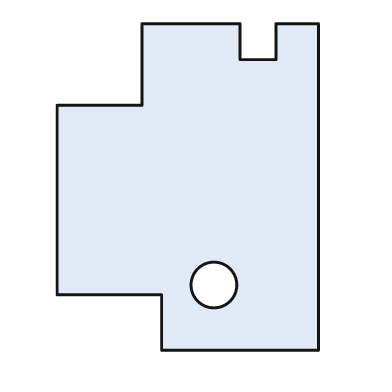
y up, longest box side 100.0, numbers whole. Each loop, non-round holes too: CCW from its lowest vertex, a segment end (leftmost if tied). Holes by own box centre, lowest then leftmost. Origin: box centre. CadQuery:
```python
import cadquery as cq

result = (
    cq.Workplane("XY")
    .moveTo(-8.0, -50.0)
    .lineTo(40.0, -50.0)
    .lineTo(40.0, 50.0)
    .lineTo(27.0, 50.0)
    .lineTo(27.0, 39.0)
    .lineTo(16.0, 39.0)
    .lineTo(16.0, 50.0)
    .lineTo(-14.0, 50.0)
    .lineTo(-14.0, 25.0)
    .lineTo(-40.0, 25.0)
    .lineTo(-40.0, -33.0)
    .lineTo(-8.0, -33.0)
    .close()
    .moveTo(8.0, -30.0)
    .circle(7.0)
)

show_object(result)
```